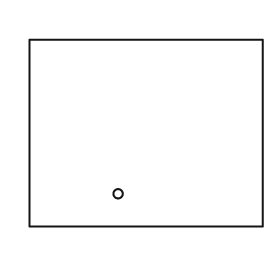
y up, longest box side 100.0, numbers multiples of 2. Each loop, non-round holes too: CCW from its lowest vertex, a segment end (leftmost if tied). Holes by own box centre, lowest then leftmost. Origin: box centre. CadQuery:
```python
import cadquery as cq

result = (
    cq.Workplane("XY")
    .moveTo(-50.0, -40.0)
    .lineTo(50.0, -40.0)
    .lineTo(50.0, 40.0)
    .lineTo(-50.0, 40.0)
    .close()
    .moveTo(-12.0, -26.0)
    .circle(2.0)
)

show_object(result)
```